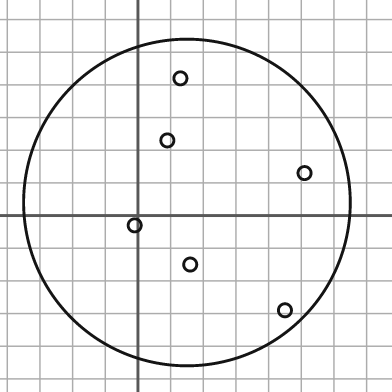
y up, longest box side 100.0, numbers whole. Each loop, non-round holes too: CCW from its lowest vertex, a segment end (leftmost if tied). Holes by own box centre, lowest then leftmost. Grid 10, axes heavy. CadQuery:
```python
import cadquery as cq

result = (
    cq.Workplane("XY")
    .moveTo(15.0, 4.0)
    .circle(50.0)
    .moveTo(45.0, -29.0)
    .circle(2.0)
    .moveTo(16.0, -15.0)
    .circle(2.0)
    .moveTo(-1.0, -3.0)
    .circle(2.0)
    .moveTo(51.0, 13.0)
    .circle(2.0)
    .moveTo(9.0, 23.0)
    .circle(2.0)
    .moveTo(13.0, 42.0)
    .circle(2.0)
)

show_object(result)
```